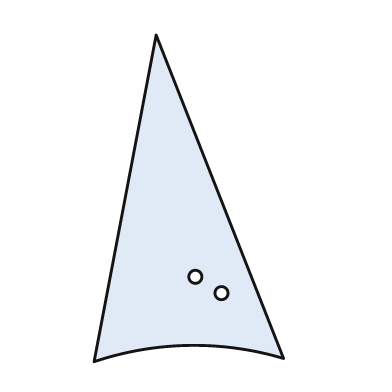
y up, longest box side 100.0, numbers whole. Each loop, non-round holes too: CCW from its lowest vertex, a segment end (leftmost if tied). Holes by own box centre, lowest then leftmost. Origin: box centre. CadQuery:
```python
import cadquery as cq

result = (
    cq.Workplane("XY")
    .moveTo(-29.0, -50.0)
    .threePointArc((0.0, -45.0), (29.0, -49.0))
    .lineTo(-10.0, 50.0)
    .close()
    .moveTo(10.0, -29.0)
    .circle(2.0)
    .moveTo(2.0, -24.0)
    .circle(2.0)
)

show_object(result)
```